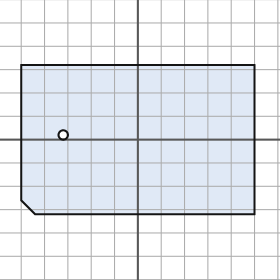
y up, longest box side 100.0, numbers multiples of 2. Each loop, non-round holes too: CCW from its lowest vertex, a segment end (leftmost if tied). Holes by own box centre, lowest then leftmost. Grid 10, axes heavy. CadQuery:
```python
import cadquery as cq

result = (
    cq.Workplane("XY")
    .moveTo(-44.0, -32.0)
    .lineTo(50.0, -32.0)
    .lineTo(50.0, 32.0)
    .lineTo(-50.0, 32.0)
    .lineTo(-50.0, -26.0)
    .close()
    .moveTo(-32.0, 2.0)
    .circle(2.0)
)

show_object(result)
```